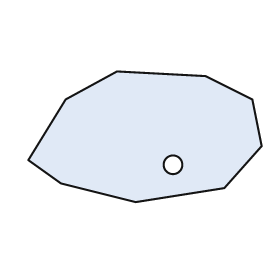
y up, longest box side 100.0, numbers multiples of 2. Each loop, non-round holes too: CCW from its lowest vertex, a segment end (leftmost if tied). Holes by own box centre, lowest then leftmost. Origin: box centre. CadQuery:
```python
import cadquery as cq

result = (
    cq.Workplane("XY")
    .moveTo(-4.0, -28.0)
    .lineTo(34.0, -22.0)
    .lineTo(50.0, -4.0)
    .lineTo(46.0, 16.0)
    .lineTo(26.0, 26.0)
    .lineTo(-12.0, 28.0)
    .lineTo(-34.0, 16.0)
    .lineTo(-50.0, -10.0)
    .lineTo(-36.0, -20.0)
    .close()
    .moveTo(12.0, -12.0)
    .circle(4.0)
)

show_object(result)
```